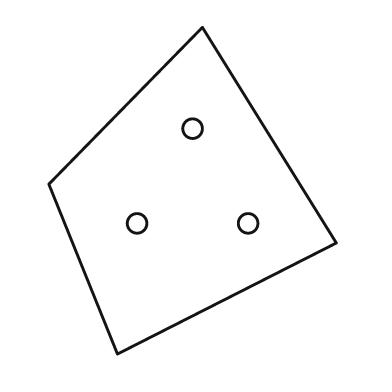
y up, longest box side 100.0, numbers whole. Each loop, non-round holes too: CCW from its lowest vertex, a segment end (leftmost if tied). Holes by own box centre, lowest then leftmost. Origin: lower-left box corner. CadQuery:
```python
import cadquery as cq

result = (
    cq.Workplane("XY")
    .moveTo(21.0, 0.0)
    .lineTo(88.0, 34.0)
    .lineTo(47.0, 100.0)
    .lineTo(0.0, 52.0)
    .close()
    .moveTo(27.0, 40.0)
    .circle(3.0)
    .moveTo(61.0, 40.0)
    .circle(3.0)
    .moveTo(44.0, 69.0)
    .circle(3.0)
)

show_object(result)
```